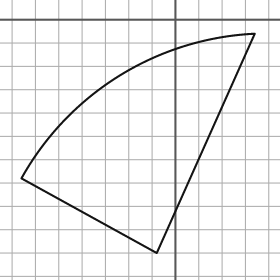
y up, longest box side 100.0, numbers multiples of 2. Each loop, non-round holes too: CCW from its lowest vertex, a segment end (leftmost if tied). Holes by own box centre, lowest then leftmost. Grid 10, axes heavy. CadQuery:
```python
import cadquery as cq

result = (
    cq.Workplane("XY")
    .moveTo(-8.0, -100.0)
    .lineTo(34.0, -6.0)
    .threePointArc((-24.0, -24.0), (-66.0, -68.0))
    .close()
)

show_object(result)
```